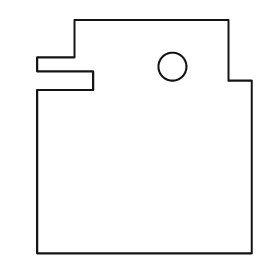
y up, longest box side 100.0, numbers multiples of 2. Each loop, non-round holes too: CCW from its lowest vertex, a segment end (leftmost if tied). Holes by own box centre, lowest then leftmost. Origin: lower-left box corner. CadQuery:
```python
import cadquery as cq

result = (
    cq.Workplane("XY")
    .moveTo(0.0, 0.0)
    .lineTo(92.0, 0.0)
    .lineTo(92.0, 74.0)
    .lineTo(82.0, 74.0)
    .lineTo(82.0, 100.0)
    .lineTo(16.0, 100.0)
    .lineTo(16.0, 84.0)
    .lineTo(0.0, 84.0)
    .lineTo(0.0, 78.0)
    .lineTo(24.0, 78.0)
    .lineTo(24.0, 70.0)
    .lineTo(0.0, 70.0)
    .close()
    .moveTo(58.0, 80.0)
    .circle(6.0)
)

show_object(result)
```